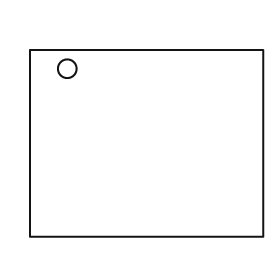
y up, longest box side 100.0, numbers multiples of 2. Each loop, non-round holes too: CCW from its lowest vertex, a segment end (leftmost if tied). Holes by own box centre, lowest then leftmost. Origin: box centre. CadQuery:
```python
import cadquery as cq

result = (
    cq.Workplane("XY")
    .moveTo(-50.0, -40.0)
    .lineTo(50.0, -40.0)
    .lineTo(50.0, 40.0)
    .lineTo(-50.0, 40.0)
    .close()
    .moveTo(-34.0, 32.0)
    .circle(4.0)
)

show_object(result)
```